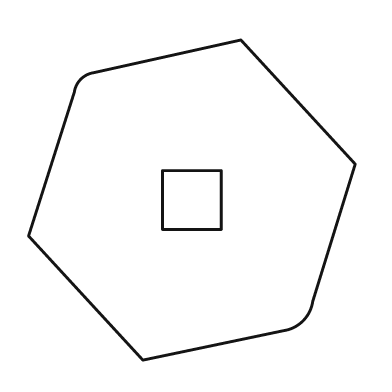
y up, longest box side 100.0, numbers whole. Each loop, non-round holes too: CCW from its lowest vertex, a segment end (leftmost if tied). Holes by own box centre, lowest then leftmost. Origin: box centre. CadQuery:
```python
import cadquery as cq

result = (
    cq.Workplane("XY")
    .moveTo(-15.0, -49.0)
    .lineTo(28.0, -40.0)
    .threePointArc((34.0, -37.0), (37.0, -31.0))
    .lineTo(50.0, 11.0)
    .lineTo(15.0, 49.0)
    .lineTo(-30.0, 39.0)
    .threePointArc((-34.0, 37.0), (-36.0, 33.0))
    .lineTo(-50.0, -11.0)
    .close()
    .moveTo(-9.0, -9.0)
    .lineTo(9.0, -9.0)
    .lineTo(9.0, 9.0)
    .lineTo(-9.0, 9.0)
    .close()
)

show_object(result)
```